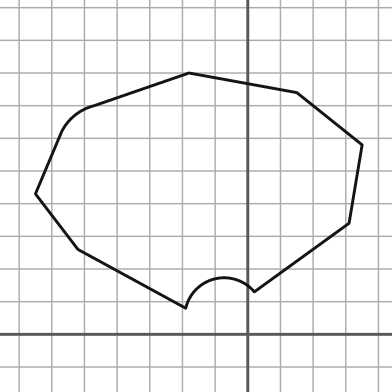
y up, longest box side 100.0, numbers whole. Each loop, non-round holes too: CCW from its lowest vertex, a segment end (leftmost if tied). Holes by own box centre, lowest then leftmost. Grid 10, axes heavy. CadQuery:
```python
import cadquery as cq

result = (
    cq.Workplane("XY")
    .moveTo(-19.0, 8.0)
    .threePointArc((-10.0, 17.0), (2.0, 13.0))
    .lineTo(31.0, 34.0)
    .lineTo(35.0, 58.0)
    .lineTo(15.0, 74.0)
    .lineTo(-18.0, 80.0)
    .lineTo(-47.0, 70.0)
    .threePointArc((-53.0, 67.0), (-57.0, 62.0))
    .lineTo(-65.0, 43.0)
    .lineTo(-52.0, 26.0)
    .close()
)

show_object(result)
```